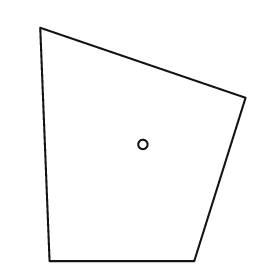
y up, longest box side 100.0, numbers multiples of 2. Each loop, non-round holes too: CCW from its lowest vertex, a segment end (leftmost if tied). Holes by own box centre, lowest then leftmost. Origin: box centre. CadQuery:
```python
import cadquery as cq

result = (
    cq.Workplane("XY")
    .moveTo(-40.0, -50.0)
    .lineTo(22.0, -50.0)
    .lineTo(44.0, 20.0)
    .lineTo(-44.0, 50.0)
    .close()
    .moveTo(0.0, 0.0)
    .circle(2.0)
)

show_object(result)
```